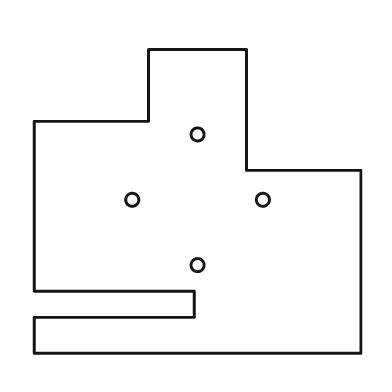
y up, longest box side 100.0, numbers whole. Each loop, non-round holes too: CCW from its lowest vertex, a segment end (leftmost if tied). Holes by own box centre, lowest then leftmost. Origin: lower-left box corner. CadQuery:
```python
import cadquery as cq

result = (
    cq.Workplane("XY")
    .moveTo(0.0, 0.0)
    .lineTo(100.0, 0.0)
    .lineTo(100.0, 56.0)
    .lineTo(65.0, 56.0)
    .lineTo(65.0, 93.0)
    .lineTo(35.0, 93.0)
    .lineTo(35.0, 71.0)
    .lineTo(0.0, 71.0)
    .lineTo(0.0, 19.0)
    .lineTo(49.0, 19.0)
    .lineTo(49.0, 11.0)
    .lineTo(0.0, 11.0)
    .close()
    .moveTo(50.0, 27.0)
    .circle(2.0)
    .moveTo(30.0, 47.0)
    .circle(2.0)
    .moveTo(70.0, 47.0)
    .circle(2.0)
    .moveTo(50.0, 67.0)
    .circle(2.0)
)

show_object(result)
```